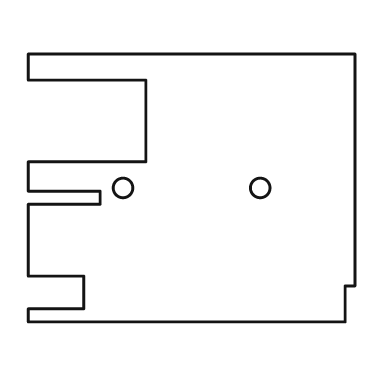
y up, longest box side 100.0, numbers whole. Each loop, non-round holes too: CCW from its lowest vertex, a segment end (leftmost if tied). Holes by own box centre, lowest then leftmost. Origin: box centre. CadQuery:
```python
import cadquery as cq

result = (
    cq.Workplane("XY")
    .moveTo(-50.0, -41.0)
    .lineTo(47.0, -41.0)
    .lineTo(47.0, -30.0)
    .lineTo(50.0, -30.0)
    .lineTo(50.0, 41.0)
    .lineTo(-50.0, 41.0)
    .lineTo(-50.0, 33.0)
    .lineTo(-14.0, 33.0)
    .lineTo(-14.0, 8.0)
    .lineTo(-50.0, 8.0)
    .lineTo(-50.0, -1.0)
    .lineTo(-28.0, -1.0)
    .lineTo(-28.0, -5.0)
    .lineTo(-50.0, -5.0)
    .lineTo(-50.0, -27.0)
    .lineTo(-33.0, -27.0)
    .lineTo(-33.0, -37.0)
    .lineTo(-50.0, -37.0)
    .close()
    .moveTo(-21.0, 0.0)
    .circle(3.0)
    .moveTo(21.0, 0.0)
    .circle(3.0)
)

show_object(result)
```